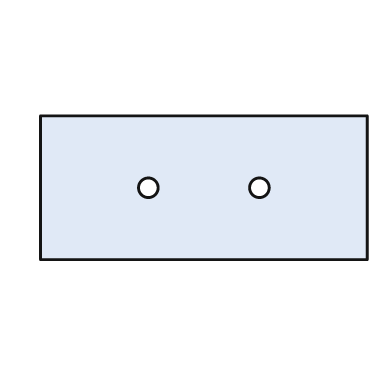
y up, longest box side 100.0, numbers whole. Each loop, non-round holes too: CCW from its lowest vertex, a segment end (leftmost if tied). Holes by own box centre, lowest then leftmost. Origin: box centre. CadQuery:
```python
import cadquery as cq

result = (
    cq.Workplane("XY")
    .moveTo(-50.0, -22.0)
    .lineTo(50.0, -22.0)
    .lineTo(50.0, 22.0)
    .lineTo(-50.0, 22.0)
    .close()
    .moveTo(-17.0, 0.0)
    .circle(3.0)
    .moveTo(17.0, 0.0)
    .circle(3.0)
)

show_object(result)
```